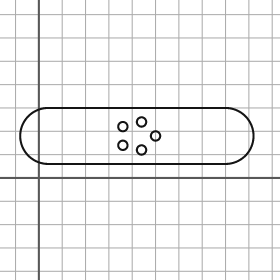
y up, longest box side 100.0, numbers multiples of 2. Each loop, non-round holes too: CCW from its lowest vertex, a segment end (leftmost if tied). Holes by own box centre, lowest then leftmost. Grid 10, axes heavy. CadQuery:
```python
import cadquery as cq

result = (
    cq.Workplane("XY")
    .moveTo(4.0, 6.0)
    .lineTo(80.0, 6.0)
    .threePointArc((92.0, 18.0), (80.0, 30.0))
    .lineTo(4.0, 30.0)
    .threePointArc((-8.0, 18.0), (4.0, 6.0))
    .close()
    .moveTo(44.0, 12.0)
    .circle(2.0)
    .moveTo(36.0, 14.0)
    .circle(2.0)
    .moveTo(50.0, 18.0)
    .circle(2.0)
    .moveTo(36.0, 22.0)
    .circle(2.0)
    .moveTo(44.0, 24.0)
    .circle(2.0)
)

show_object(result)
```